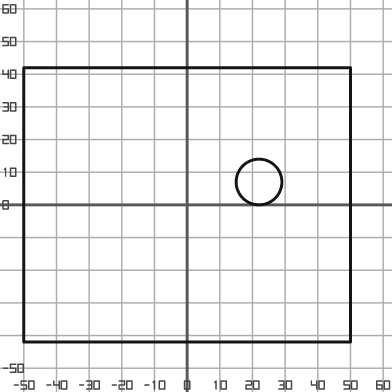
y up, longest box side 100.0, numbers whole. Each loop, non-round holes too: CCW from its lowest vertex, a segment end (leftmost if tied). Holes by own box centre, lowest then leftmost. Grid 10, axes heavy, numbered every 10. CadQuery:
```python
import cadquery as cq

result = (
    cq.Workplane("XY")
    .moveTo(-50.0, -42.0)
    .lineTo(50.0, -42.0)
    .lineTo(50.0, 42.0)
    .lineTo(-50.0, 42.0)
    .close()
    .moveTo(22.0, 7.0)
    .circle(7.0)
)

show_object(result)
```